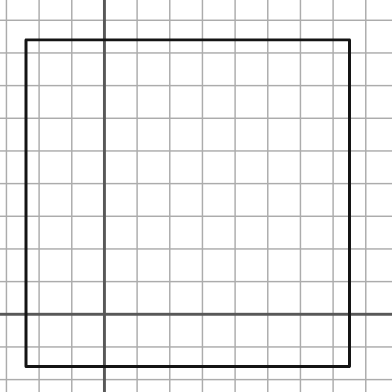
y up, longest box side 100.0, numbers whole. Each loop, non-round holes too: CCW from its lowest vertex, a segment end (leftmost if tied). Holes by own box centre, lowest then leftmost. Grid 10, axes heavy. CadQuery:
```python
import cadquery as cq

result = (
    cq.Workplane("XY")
    .moveTo(-24.0, -16.0)
    .lineTo(75.0, -16.0)
    .lineTo(75.0, 84.0)
    .lineTo(-24.0, 84.0)
    .close()
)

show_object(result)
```